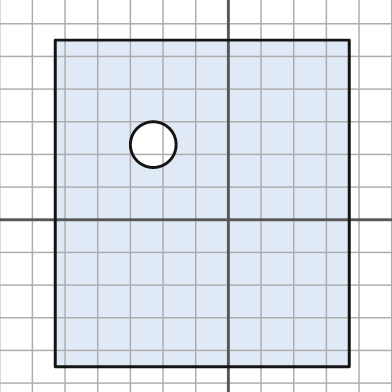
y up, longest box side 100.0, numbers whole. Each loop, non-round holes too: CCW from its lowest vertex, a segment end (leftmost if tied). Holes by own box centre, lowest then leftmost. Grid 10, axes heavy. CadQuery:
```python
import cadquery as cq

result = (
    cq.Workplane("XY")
    .moveTo(-53.0, -45.0)
    .lineTo(37.0, -45.0)
    .lineTo(37.0, 55.0)
    .lineTo(-53.0, 55.0)
    .close()
    .moveTo(-23.0, 23.0)
    .circle(7.0)
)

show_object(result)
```